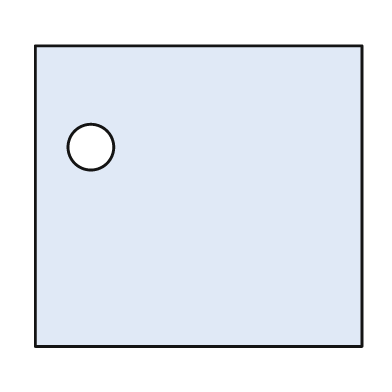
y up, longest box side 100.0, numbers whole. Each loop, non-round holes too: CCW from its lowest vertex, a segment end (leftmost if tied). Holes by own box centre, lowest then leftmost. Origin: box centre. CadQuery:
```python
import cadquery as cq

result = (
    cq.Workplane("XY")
    .moveTo(-50.0, -46.0)
    .lineTo(50.0, -46.0)
    .lineTo(50.0, 46.0)
    .lineTo(-50.0, 46.0)
    .close()
    .moveTo(-33.0, 15.0)
    .circle(7.0)
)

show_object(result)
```